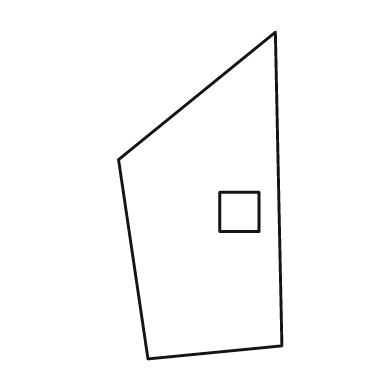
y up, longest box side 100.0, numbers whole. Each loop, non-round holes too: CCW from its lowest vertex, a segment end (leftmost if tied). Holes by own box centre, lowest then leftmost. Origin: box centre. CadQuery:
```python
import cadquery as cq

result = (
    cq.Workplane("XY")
    .moveTo(-16.0, -50.0)
    .lineTo(25.0, -46.0)
    .lineTo(23.0, 50.0)
    .lineTo(-25.0, 11.0)
    .close()
    .moveTo(6.0, -11.0)
    .lineTo(18.0, -11.0)
    .lineTo(18.0, 1.0)
    .lineTo(6.0, 1.0)
    .close()
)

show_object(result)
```